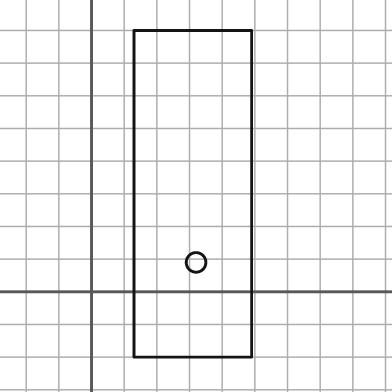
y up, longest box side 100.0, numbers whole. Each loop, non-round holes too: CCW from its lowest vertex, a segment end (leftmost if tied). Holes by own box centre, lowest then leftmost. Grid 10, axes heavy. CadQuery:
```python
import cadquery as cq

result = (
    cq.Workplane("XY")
    .moveTo(13.0, -20.0)
    .lineTo(49.0, -20.0)
    .lineTo(49.0, 80.0)
    .lineTo(13.0, 80.0)
    .close()
    .moveTo(32.0, 9.0)
    .circle(3.0)
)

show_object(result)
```